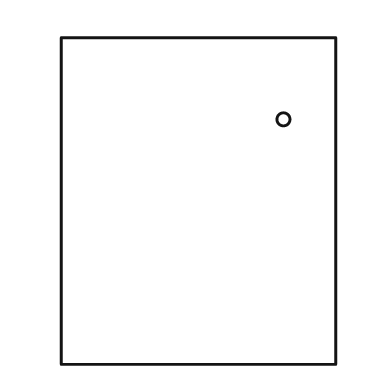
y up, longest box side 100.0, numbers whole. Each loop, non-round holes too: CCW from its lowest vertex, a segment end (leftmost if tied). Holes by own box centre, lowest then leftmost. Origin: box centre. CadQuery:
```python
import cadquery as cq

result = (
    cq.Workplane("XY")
    .moveTo(-42.0, -50.0)
    .lineTo(42.0, -50.0)
    .lineTo(42.0, 50.0)
    .lineTo(-42.0, 50.0)
    .close()
    .moveTo(26.0, 25.0)
    .circle(2.0)
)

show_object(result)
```